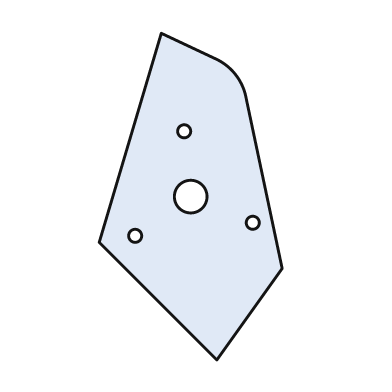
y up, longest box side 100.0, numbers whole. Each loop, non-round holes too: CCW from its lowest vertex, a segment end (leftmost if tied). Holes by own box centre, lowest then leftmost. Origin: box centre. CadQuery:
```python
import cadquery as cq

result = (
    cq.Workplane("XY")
    .moveTo(8.0, -50.0)
    .lineTo(28.0, -22.0)
    .lineTo(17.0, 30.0)
    .threePointArc((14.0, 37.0), (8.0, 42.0))
    .lineTo(-9.0, 50.0)
    .lineTo(-28.0, -14.0)
    .close()
    .moveTo(-17.0, -12.0)
    .circle(2.0)
    .moveTo(19.0, -8.0)
    .circle(2.0)
    .moveTo(0.0, 0.0)
    .circle(5.0)
    .moveTo(-2.0, 20.0)
    .circle(2.0)
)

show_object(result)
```